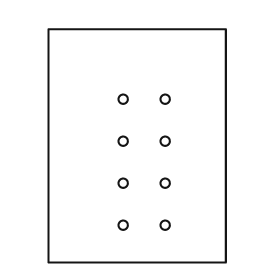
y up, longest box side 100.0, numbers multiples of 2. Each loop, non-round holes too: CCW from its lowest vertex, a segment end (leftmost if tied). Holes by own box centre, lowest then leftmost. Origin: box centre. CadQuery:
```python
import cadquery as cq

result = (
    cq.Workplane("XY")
    .moveTo(-38.0, -50.0)
    .lineTo(38.0, -50.0)
    .lineTo(38.0, 50.0)
    .lineTo(-38.0, 50.0)
    .close()
    .moveTo(-6.0, -34.0)
    .circle(2.0)
    .moveTo(12.0, -34.0)
    .circle(2.0)
    .moveTo(-6.0, -16.0)
    .circle(2.0)
    .moveTo(12.0, -16.0)
    .circle(2.0)
    .moveTo(-6.0, 2.0)
    .circle(2.0)
    .moveTo(12.0, 2.0)
    .circle(2.0)
    .moveTo(-6.0, 20.0)
    .circle(2.0)
    .moveTo(12.0, 20.0)
    .circle(2.0)
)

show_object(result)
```